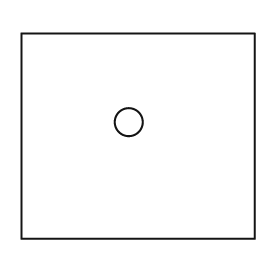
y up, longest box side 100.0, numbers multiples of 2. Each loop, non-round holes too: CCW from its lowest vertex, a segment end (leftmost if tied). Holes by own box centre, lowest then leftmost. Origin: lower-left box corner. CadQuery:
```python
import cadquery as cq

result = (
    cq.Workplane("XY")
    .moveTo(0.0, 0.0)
    .lineTo(100.0, 0.0)
    .lineTo(100.0, 88.0)
    .lineTo(0.0, 88.0)
    .close()
    .moveTo(46.0, 50.0)
    .circle(6.0)
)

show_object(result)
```